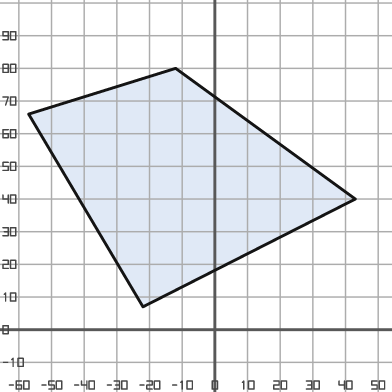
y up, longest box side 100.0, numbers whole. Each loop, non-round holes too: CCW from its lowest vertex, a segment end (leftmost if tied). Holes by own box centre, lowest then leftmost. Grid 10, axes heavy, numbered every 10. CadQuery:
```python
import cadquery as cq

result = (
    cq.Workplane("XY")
    .moveTo(-22.0, 7.0)
    .lineTo(43.0, 40.0)
    .lineTo(-12.0, 80.0)
    .lineTo(-57.0, 66.0)
    .close()
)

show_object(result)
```